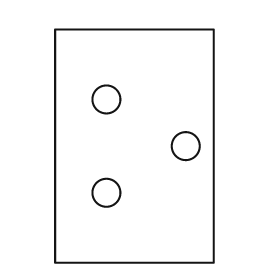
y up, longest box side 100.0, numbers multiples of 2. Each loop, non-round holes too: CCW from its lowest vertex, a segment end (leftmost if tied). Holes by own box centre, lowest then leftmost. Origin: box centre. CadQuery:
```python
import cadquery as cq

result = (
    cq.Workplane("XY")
    .moveTo(-34.0, -50.0)
    .lineTo(34.0, -50.0)
    .lineTo(34.0, 50.0)
    .lineTo(-34.0, 50.0)
    .close()
    .moveTo(-12.0, -20.0)
    .circle(6.0)
    .moveTo(22.0, 0.0)
    .circle(6.0)
    .moveTo(-12.0, 20.0)
    .circle(6.0)
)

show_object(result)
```